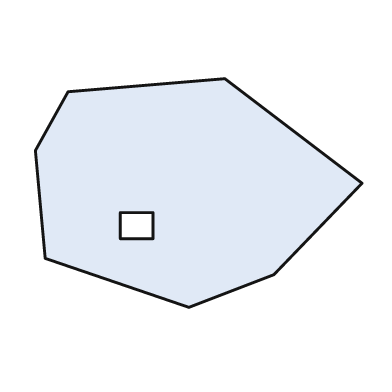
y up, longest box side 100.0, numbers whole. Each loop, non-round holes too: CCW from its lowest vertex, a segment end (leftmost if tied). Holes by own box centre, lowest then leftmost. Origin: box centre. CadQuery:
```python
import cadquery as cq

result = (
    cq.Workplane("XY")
    .moveTo(-3.0, -35.0)
    .lineTo(23.0, -25.0)
    .lineTo(50.0, 3.0)
    .lineTo(8.0, 35.0)
    .lineTo(-40.0, 31.0)
    .lineTo(-50.0, 13.0)
    .lineTo(-47.0, -20.0)
    .close()
    .moveTo(-24.0, -14.0)
    .lineTo(-14.0, -14.0)
    .lineTo(-14.0, -6.0)
    .lineTo(-24.0, -6.0)
    .close()
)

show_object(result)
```